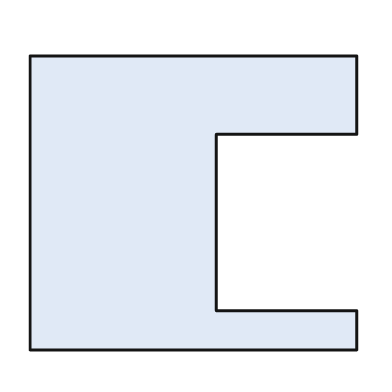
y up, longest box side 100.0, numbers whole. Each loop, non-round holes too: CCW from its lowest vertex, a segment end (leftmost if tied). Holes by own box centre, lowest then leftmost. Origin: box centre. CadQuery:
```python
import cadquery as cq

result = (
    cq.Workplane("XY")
    .moveTo(-50.0, -45.0)
    .lineTo(50.0, -45.0)
    .lineTo(50.0, -33.0)
    .lineTo(7.0, -33.0)
    .lineTo(7.0, 21.0)
    .lineTo(50.0, 21.0)
    .lineTo(50.0, 45.0)
    .lineTo(-50.0, 45.0)
    .close()
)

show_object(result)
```